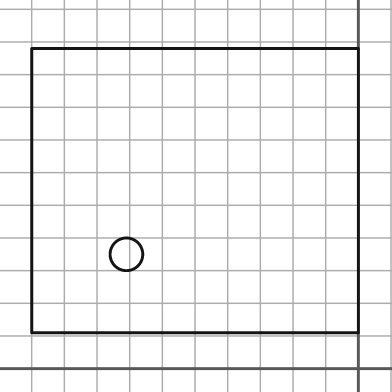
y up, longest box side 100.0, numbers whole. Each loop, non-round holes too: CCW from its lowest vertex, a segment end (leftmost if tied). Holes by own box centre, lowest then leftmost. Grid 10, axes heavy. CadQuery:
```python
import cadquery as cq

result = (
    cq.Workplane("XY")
    .moveTo(-100.0, 11.0)
    .lineTo(0.0, 11.0)
    .lineTo(0.0, 98.0)
    .lineTo(-100.0, 98.0)
    .close()
    .moveTo(-71.0, 35.0)
    .circle(5.0)
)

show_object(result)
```